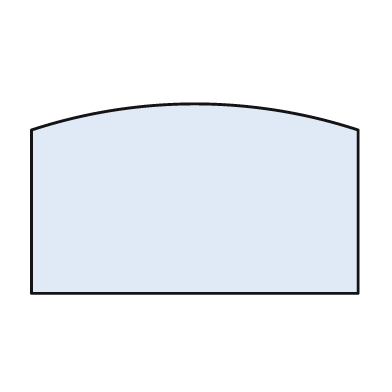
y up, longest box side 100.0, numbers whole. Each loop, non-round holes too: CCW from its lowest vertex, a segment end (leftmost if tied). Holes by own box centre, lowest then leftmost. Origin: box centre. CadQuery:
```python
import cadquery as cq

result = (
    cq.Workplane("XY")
    .moveTo(-50.0, -29.0)
    .lineTo(50.0, -29.0)
    .lineTo(50.0, 21.0)
    .threePointArc((0.0, 29.0), (-50.0, 21.0))
    .close()
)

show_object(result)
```